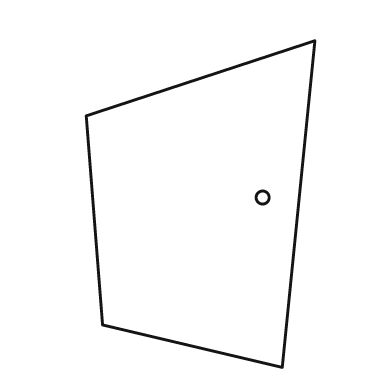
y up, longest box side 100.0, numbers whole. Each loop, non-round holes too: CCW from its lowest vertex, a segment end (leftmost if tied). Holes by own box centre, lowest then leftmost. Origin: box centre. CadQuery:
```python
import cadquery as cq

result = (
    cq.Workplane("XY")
    .moveTo(25.0, -50.0)
    .lineTo(35.0, 50.0)
    .lineTo(-35.0, 27.0)
    .lineTo(-30.0, -37.0)
    .close()
    .moveTo(19.0, 2.0)
    .circle(2.0)
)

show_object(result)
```